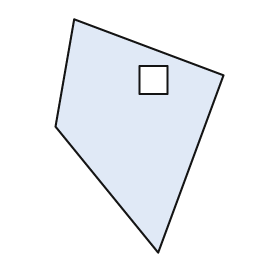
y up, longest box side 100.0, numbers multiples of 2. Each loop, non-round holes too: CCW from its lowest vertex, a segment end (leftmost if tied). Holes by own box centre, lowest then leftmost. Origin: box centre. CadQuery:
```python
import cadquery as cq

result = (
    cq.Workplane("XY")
    .moveTo(8.0, -50.0)
    .lineTo(36.0, 26.0)
    .lineTo(-28.0, 50.0)
    .lineTo(-36.0, 4.0)
    .close()
    .moveTo(0.0, 18.0)
    .lineTo(12.0, 18.0)
    .lineTo(12.0, 30.0)
    .lineTo(0.0, 30.0)
    .close()
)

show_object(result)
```